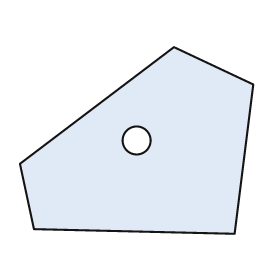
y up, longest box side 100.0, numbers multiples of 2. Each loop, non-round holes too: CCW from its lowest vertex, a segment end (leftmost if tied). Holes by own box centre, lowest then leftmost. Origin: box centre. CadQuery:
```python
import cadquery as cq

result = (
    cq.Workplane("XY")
    .moveTo(42.0, -40.0)
    .lineTo(50.0, 24.0)
    .lineTo(16.0, 40.0)
    .lineTo(-50.0, -10.0)
    .lineTo(-44.0, -38.0)
    .close()
    .moveTo(0.0, 0.0)
    .circle(6.0)
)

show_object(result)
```